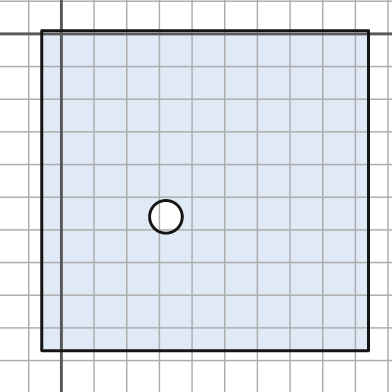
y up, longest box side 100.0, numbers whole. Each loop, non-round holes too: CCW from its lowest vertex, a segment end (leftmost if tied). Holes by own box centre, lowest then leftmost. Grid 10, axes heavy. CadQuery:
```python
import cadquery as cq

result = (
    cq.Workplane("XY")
    .moveTo(-6.0, -97.0)
    .lineTo(94.0, -97.0)
    .lineTo(94.0, 1.0)
    .lineTo(-6.0, 1.0)
    .close()
    .moveTo(32.0, -56.0)
    .circle(5.0)
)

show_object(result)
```